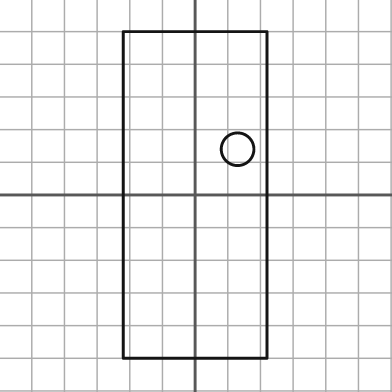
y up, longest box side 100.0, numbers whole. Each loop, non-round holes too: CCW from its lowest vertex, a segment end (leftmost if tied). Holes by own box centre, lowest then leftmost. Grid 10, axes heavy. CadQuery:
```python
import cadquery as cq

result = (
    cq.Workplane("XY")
    .moveTo(-22.0, -50.0)
    .lineTo(22.0, -50.0)
    .lineTo(22.0, 50.0)
    .lineTo(-22.0, 50.0)
    .close()
    .moveTo(13.0, 14.0)
    .circle(5.0)
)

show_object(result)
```